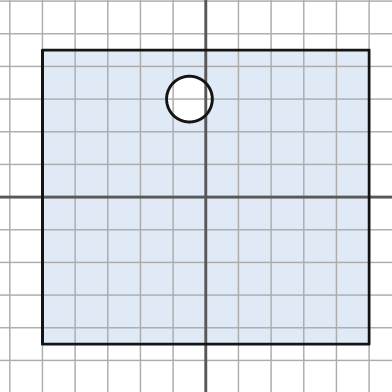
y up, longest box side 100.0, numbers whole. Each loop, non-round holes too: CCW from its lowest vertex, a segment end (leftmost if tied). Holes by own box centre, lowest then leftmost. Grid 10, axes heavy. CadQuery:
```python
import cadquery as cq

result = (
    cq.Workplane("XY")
    .moveTo(-50.0, -45.0)
    .lineTo(50.0, -45.0)
    .lineTo(50.0, 45.0)
    .lineTo(-50.0, 45.0)
    .close()
    .moveTo(-5.0, 30.0)
    .circle(7.0)
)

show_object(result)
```